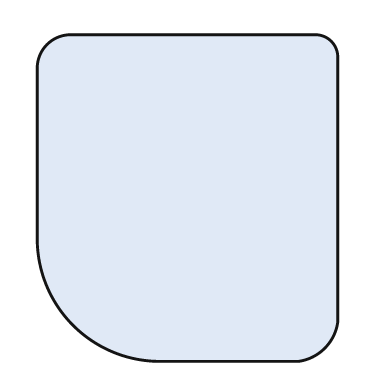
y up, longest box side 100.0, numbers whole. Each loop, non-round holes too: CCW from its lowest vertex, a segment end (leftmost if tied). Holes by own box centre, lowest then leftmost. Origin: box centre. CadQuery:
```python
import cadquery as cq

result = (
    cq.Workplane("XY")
    .moveTo(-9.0, -50.0)
    .lineTo(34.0, -50.0)
    .threePointArc((42.0, -46.0), (46.0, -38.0))
    .lineTo(46.0, 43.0)
    .threePointArc((44.0, 48.0), (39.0, 50.0))
    .lineTo(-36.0, 50.0)
    .threePointArc((-43.0, 47.0), (-46.0, 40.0))
    .lineTo(-46.0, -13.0)
    .threePointArc((-35.0, -39.0), (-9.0, -50.0))
    .close()
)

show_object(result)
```